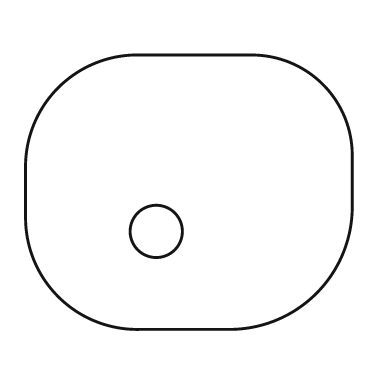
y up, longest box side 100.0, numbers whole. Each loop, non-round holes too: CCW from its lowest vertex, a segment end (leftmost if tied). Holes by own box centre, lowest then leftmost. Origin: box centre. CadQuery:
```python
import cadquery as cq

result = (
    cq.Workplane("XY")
    .moveTo(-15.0, -42.0)
    .lineTo(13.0, -42.0)
    .threePointArc((39.0, -31.0), (50.0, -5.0))
    .lineTo(50.0, 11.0)
    .threePointArc((41.0, 33.0), (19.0, 42.0))
    .lineTo(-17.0, 42.0)
    .threePointArc((-40.0, 32.0), (-50.0, 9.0))
    .lineTo(-50.0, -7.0)
    .threePointArc((-40.0, -32.0), (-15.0, -42.0))
    .close()
    .moveTo(-10.0, -12.0)
    .circle(8.0)
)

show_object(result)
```